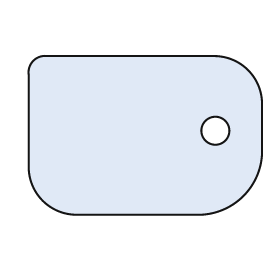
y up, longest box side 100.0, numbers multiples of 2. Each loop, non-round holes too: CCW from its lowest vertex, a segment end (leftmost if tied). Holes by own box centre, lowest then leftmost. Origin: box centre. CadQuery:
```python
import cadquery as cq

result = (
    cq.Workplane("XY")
    .moveTo(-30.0, -34.0)
    .lineTo(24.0, -34.0)
    .threePointArc((42.0, -26.0), (50.0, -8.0))
    .lineTo(50.0, 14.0)
    .threePointArc((44.0, 28.0), (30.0, 34.0))
    .lineTo(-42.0, 34.0)
    .threePointArc((-48.0, 32.0), (-50.0, 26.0))
    .lineTo(-50.0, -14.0)
    .threePointArc((-44.0, -28.0), (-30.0, -34.0))
    .close()
    .moveTo(30.0, 2.0)
    .circle(6.0)
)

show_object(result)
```